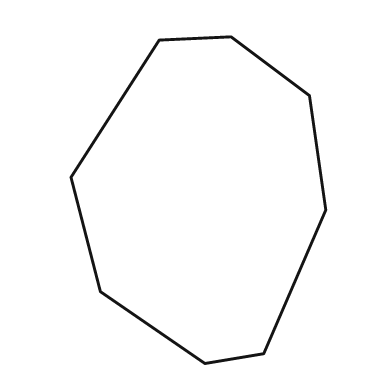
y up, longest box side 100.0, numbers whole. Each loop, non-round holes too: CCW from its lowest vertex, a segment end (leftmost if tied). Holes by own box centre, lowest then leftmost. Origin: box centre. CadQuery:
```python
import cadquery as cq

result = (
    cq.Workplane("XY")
    .moveTo(2.0, -50.0)
    .lineTo(20.0, -47.0)
    .lineTo(39.0, -3.0)
    .lineTo(34.0, 32.0)
    .lineTo(10.0, 50.0)
    .lineTo(-12.0, 49.0)
    .lineTo(-39.0, 7.0)
    .lineTo(-30.0, -28.0)
    .close()
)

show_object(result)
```